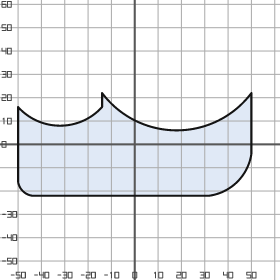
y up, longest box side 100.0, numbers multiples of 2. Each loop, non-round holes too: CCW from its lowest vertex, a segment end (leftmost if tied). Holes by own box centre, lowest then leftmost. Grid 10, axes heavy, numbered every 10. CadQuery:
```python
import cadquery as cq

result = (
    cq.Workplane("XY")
    .moveTo(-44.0, -22.0)
    .lineTo(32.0, -22.0)
    .threePointArc((44.0, -16.0), (50.0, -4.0))
    .lineTo(50.0, 22.0)
    .threePointArc((18.0, 6.0), (-14.0, 22.0))
    .lineTo(-14.0, 16.0)
    .threePointArc((-32.0, 8.0), (-50.0, 16.0))
    .lineTo(-50.0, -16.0)
    .threePointArc((-48.0, -20.0), (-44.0, -22.0))
    .close()
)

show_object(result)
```